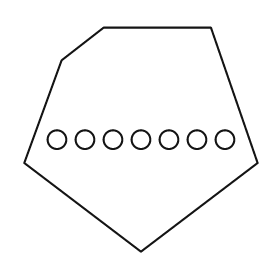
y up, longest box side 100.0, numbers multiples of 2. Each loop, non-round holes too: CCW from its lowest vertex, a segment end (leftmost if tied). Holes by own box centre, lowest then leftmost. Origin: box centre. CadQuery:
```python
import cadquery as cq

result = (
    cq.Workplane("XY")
    .moveTo(0.0, -48.0)
    .lineTo(50.0, -10.0)
    .lineTo(30.0, 48.0)
    .lineTo(-16.0, 48.0)
    .lineTo(-34.0, 34.0)
    .lineTo(-50.0, -10.0)
    .close()
    .moveTo(-36.0, 0.0)
    .circle(4.0)
    .moveTo(-24.0, 0.0)
    .circle(4.0)
    .moveTo(-12.0, 0.0)
    .circle(4.0)
    .moveTo(0.0, 0.0)
    .circle(4.0)
    .moveTo(12.0, 0.0)
    .circle(4.0)
    .moveTo(24.0, 0.0)
    .circle(4.0)
    .moveTo(36.0, 0.0)
    .circle(4.0)
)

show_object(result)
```